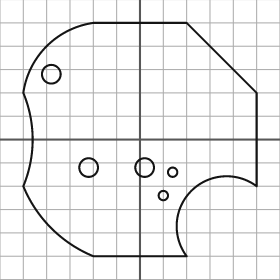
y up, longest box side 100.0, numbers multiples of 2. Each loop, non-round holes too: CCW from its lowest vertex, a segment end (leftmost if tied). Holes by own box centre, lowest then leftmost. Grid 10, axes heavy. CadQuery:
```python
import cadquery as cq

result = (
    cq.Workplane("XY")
    .moveTo(-20.0, -50.0)
    .lineTo(20.0, -50.0)
    .threePointArc((22.0, -22.0), (50.0, -20.0))
    .lineTo(50.0, 20.0)
    .lineTo(20.0, 50.0)
    .lineTo(-20.0, 50.0)
    .threePointArc((-40.0, 40.0), (-50.0, 20.0))
    .threePointArc((-46.0, 0.0), (-50.0, -20.0))
    .threePointArc((-38.0, -38.0), (-20.0, -50.0))
    .close()
    .moveTo(10.0, -24.0)
    .circle(2.0)
    .moveTo(14.0, -14.0)
    .circle(2.0)
    .moveTo(-22.0, -12.0)
    .circle(4.0)
    .moveTo(2.0, -12.0)
    .circle(4.0)
    .moveTo(-38.0, 28.0)
    .circle(4.0)
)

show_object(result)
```